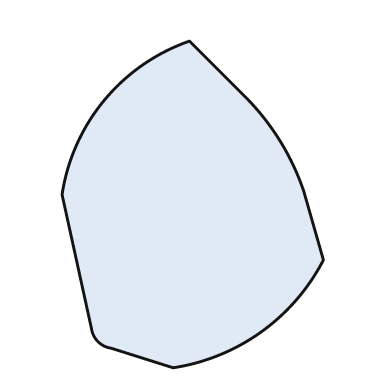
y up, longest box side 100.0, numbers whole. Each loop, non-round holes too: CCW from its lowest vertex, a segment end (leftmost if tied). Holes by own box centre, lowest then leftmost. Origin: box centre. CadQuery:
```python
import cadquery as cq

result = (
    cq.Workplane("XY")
    .moveTo(-6.0, -50.0)
    .threePointArc((21.0, -39.0), (40.0, -17.0))
    .lineTo(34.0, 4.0)
    .threePointArc((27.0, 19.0), (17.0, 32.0))
    .lineTo(-1.0, 50.0)
    .threePointArc((-27.0, 32.0), (-40.0, 3.0))
    .lineTo(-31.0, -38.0)
    .threePointArc((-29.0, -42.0), (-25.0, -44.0))
    .close()
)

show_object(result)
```